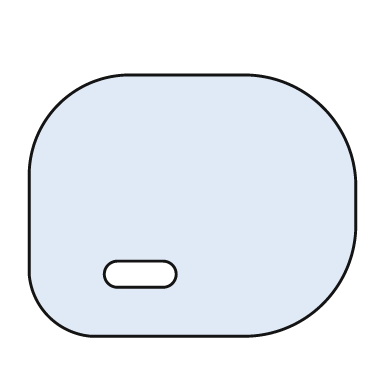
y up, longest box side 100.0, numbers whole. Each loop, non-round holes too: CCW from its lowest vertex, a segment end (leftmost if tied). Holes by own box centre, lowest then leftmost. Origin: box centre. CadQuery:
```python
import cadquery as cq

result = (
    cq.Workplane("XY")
    .moveTo(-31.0, -40.0)
    .lineTo(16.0, -40.0)
    .threePointArc((40.0, -30.0), (50.0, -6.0))
    .lineTo(50.0, 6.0)
    .threePointArc((40.0, 30.0), (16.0, 40.0))
    .lineTo(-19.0, 40.0)
    .threePointArc((-41.0, 31.0), (-50.0, 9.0))
    .lineTo(-50.0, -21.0)
    .threePointArc((-44.0, -34.0), (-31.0, -40.0))
    .close()
    .moveTo(-23.0, -25.0)
    .lineTo(-9.0, -25.0)
    .threePointArc((-5.0, -21.0), (-9.0, -17.0))
    .lineTo(-23.0, -17.0)
    .threePointArc((-27.0, -21.0), (-23.0, -25.0))
    .close()
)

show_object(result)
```